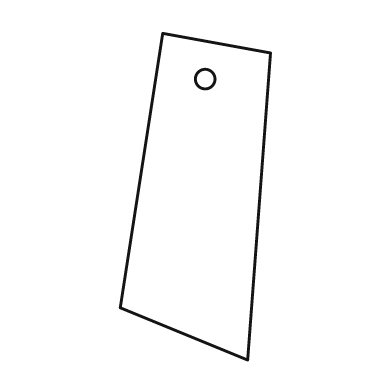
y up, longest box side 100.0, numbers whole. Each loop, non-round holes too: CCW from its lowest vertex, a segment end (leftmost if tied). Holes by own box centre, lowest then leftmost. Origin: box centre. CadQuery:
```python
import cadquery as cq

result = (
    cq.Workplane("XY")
    .moveTo(16.0, -50.0)
    .lineTo(23.0, 44.0)
    .lineTo(-10.0, 50.0)
    .lineTo(-23.0, -34.0)
    .close()
    .moveTo(3.0, 36.0)
    .circle(3.0)
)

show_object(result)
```